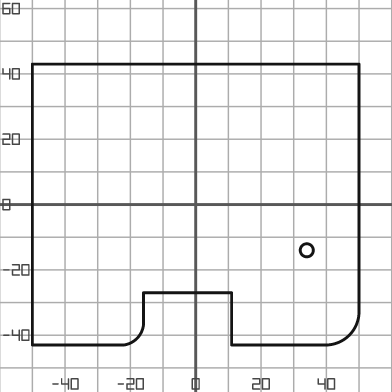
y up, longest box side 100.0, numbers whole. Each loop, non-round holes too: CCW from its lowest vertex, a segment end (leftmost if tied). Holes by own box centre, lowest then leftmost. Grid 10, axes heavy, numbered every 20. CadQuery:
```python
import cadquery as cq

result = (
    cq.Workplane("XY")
    .moveTo(-50.0, -43.0)
    .lineTo(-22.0, -43.0)
    .threePointArc((-18.0, -41.0), (-16.0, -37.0))
    .lineTo(-16.0, -27.0)
    .lineTo(11.0, -27.0)
    .lineTo(11.0, -43.0)
    .lineTo(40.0, -43.0)
    .threePointArc((47.0, -40.0), (50.0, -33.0))
    .lineTo(50.0, 43.0)
    .lineTo(-50.0, 43.0)
    .close()
    .moveTo(34.0, -14.0)
    .circle(2.0)
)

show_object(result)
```